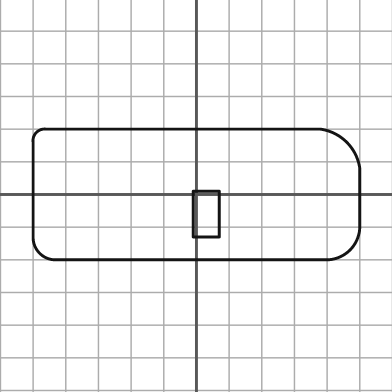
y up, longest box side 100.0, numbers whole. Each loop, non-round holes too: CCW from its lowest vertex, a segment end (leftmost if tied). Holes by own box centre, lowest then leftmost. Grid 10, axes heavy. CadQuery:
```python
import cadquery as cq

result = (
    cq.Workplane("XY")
    .moveTo(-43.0, -20.0)
    .lineTo(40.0, -20.0)
    .threePointArc((47.0, -17.0), (50.0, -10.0))
    .lineTo(50.0, 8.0)
    .threePointArc((46.0, 16.0), (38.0, 20.0))
    .lineTo(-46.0, 20.0)
    .threePointArc((-49.0, 19.0), (-50.0, 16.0))
    .lineTo(-50.0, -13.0)
    .threePointArc((-48.0, -18.0), (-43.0, -20.0))
    .close()
    .moveTo(-1.0, -13.0)
    .lineTo(7.0, -13.0)
    .lineTo(7.0, 1.0)
    .lineTo(-1.0, 1.0)
    .close()
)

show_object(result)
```